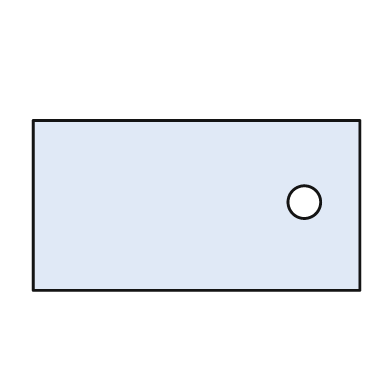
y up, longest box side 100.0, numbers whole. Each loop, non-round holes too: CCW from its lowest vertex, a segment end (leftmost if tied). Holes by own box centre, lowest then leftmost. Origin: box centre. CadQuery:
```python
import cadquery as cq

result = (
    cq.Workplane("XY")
    .moveTo(-50.0, -26.0)
    .lineTo(50.0, -26.0)
    .lineTo(50.0, 26.0)
    .lineTo(-50.0, 26.0)
    .close()
    .moveTo(33.0, 1.0)
    .circle(5.0)
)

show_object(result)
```